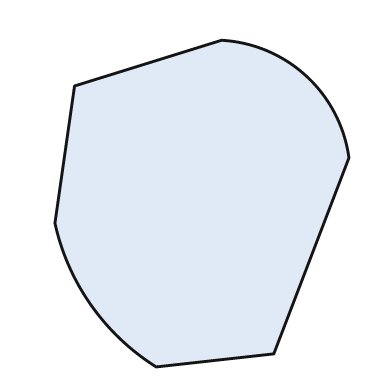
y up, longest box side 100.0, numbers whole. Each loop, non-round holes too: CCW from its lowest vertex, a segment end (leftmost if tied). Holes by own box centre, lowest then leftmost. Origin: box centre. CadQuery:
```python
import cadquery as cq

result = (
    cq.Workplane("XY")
    .moveTo(-14.0, -50.0)
    .lineTo(22.0, -46.0)
    .lineTo(45.0, 14.0)
    .threePointArc((32.0, 39.0), (6.0, 50.0))
    .lineTo(-39.0, 36.0)
    .lineTo(-45.0, -6.0)
    .threePointArc((-34.0, -31.0), (-14.0, -50.0))
    .close()
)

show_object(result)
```